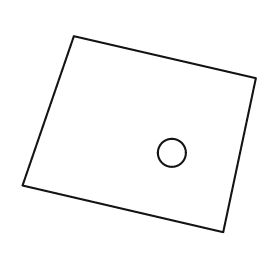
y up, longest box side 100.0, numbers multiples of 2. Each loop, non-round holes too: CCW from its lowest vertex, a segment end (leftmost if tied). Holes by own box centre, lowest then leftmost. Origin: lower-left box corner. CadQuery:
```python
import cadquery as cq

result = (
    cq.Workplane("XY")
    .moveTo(86.0, 0.0)
    .lineTo(100.0, 66.0)
    .lineTo(22.0, 84.0)
    .lineTo(0.0, 20.0)
    .close()
    .moveTo(64.0, 34.0)
    .circle(6.0)
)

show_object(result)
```